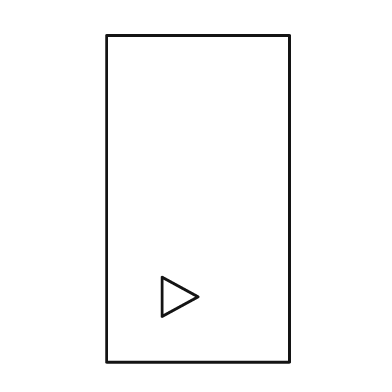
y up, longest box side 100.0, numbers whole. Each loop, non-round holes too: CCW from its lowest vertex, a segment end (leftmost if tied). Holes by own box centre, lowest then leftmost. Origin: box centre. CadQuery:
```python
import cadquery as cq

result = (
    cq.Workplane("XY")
    .moveTo(-28.0, -50.0)
    .lineTo(28.0, -50.0)
    .lineTo(28.0, 50.0)
    .lineTo(-28.0, 50.0)
    .close()
    .moveTo(-11.0, -36.0)
    .lineTo(0.0, -30.0)
    .lineTo(-11.0, -24.0)
    .close()
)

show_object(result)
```